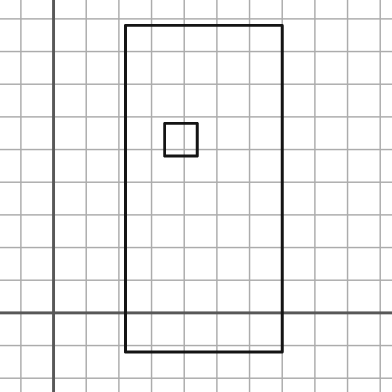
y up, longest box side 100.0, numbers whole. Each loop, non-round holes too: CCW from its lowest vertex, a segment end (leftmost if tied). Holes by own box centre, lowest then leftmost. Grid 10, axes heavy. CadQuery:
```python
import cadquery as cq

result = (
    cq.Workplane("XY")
    .moveTo(22.0, -12.0)
    .lineTo(70.0, -12.0)
    .lineTo(70.0, 88.0)
    .lineTo(22.0, 88.0)
    .close()
    .moveTo(34.0, 48.0)
    .lineTo(44.0, 48.0)
    .lineTo(44.0, 58.0)
    .lineTo(34.0, 58.0)
    .close()
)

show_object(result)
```